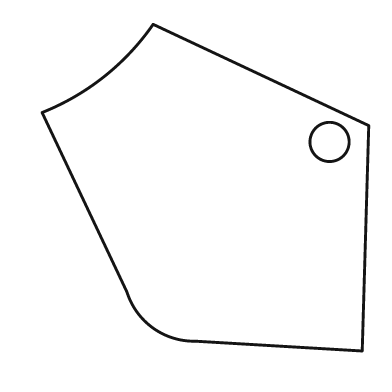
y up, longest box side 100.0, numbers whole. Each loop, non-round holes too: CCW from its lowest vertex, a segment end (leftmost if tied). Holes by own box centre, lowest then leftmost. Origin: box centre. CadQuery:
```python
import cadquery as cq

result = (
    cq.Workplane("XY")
    .moveTo(48.0, -50.0)
    .lineTo(50.0, 19.0)
    .lineTo(-16.0, 50.0)
    .threePointArc((-31.0, 34.0), (-50.0, 23.0))
    .lineTo(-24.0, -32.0)
    .threePointArc((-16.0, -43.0), (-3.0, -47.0))
    .close()
    .moveTo(38.0, 14.0)
    .circle(6.0)
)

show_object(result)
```